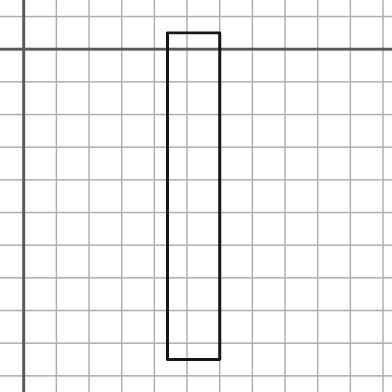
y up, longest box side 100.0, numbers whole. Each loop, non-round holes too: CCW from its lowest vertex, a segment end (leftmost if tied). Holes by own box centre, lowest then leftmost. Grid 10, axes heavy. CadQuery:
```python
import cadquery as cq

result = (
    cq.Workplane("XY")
    .moveTo(44.0, -95.0)
    .lineTo(60.0, -95.0)
    .lineTo(60.0, 5.0)
    .lineTo(44.0, 5.0)
    .close()
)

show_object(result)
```